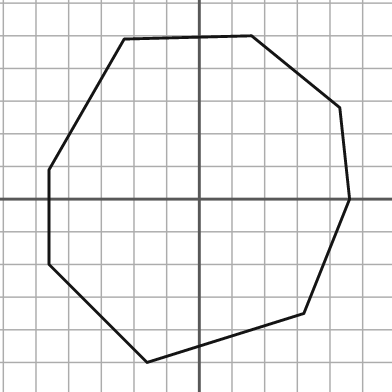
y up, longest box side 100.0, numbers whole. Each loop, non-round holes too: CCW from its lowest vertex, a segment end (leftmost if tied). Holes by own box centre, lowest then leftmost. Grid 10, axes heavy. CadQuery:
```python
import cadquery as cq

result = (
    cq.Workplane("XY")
    .moveTo(-16.0, -50.0)
    .lineTo(32.0, -35.0)
    .lineTo(46.0, 0.0)
    .lineTo(43.0, 28.0)
    .lineTo(16.0, 50.0)
    .lineTo(-23.0, 49.0)
    .lineTo(-46.0, 9.0)
    .lineTo(-46.0, -20.0)
    .close()
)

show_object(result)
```